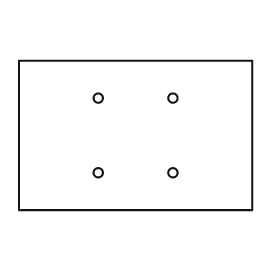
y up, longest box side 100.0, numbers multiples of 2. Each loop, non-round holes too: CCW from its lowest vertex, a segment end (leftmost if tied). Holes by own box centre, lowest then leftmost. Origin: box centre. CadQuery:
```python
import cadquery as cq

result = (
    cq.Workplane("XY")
    .moveTo(-50.0, -32.0)
    .lineTo(50.0, -32.0)
    .lineTo(50.0, 32.0)
    .lineTo(-50.0, 32.0)
    .close()
    .moveTo(-16.0, -16.0)
    .circle(2.0)
    .moveTo(16.0, -16.0)
    .circle(2.0)
    .moveTo(-16.0, 16.0)
    .circle(2.0)
    .moveTo(16.0, 16.0)
    .circle(2.0)
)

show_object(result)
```